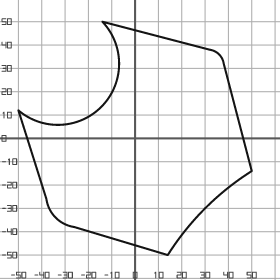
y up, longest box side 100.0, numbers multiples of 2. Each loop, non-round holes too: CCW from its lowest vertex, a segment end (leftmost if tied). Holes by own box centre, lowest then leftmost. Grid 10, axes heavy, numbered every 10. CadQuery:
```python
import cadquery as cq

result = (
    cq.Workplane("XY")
    .moveTo(14.0, -50.0)
    .threePointArc((30.0, -30.0), (50.0, -14.0))
    .lineTo(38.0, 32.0)
    .threePointArc((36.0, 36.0), (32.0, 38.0))
    .lineTo(-14.0, 50.0)
    .threePointArc((-14.0, 14.0), (-50.0, 12.0))
    .lineTo(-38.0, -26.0)
    .threePointArc((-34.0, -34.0), (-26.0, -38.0))
    .close()
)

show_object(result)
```